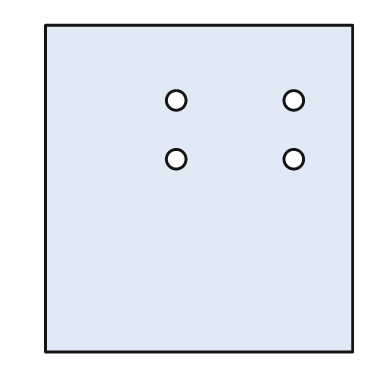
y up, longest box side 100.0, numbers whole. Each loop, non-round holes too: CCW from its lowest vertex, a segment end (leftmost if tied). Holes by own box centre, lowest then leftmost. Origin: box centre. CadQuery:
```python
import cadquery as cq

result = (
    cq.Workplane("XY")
    .moveTo(-47.0, -50.0)
    .lineTo(47.0, -50.0)
    .lineTo(47.0, 50.0)
    .lineTo(-47.0, 50.0)
    .close()
    .moveTo(-7.0, 9.0)
    .circle(3.0)
    .moveTo(29.0, 9.0)
    .circle(3.0)
    .moveTo(-7.0, 27.0)
    .circle(3.0)
    .moveTo(29.0, 27.0)
    .circle(3.0)
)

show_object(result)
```